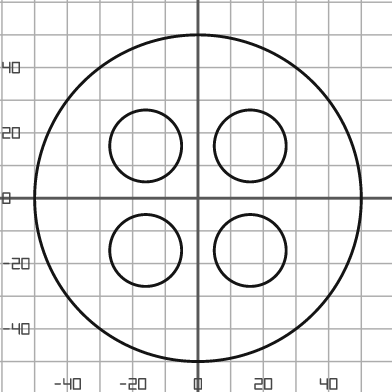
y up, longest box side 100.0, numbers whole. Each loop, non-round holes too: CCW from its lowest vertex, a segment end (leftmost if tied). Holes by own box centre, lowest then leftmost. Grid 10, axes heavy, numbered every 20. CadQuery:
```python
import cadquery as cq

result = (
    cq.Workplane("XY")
    .moveTo(0.0, 0.0)
    .circle(50.0)
    .moveTo(-16.0, -16.0)
    .circle(11.0)
    .moveTo(16.0, -16.0)
    .circle(11.0)
    .moveTo(-16.0, 16.0)
    .circle(11.0)
    .moveTo(16.0, 16.0)
    .circle(11.0)
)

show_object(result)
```